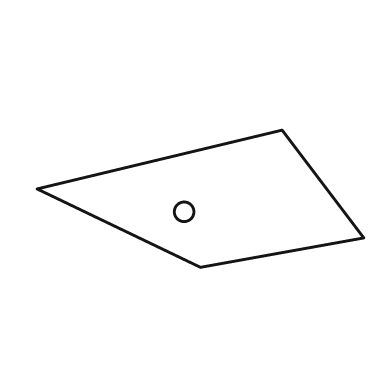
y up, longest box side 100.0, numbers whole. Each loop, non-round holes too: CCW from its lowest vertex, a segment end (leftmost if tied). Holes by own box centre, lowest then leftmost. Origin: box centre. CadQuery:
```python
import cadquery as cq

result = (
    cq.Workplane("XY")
    .moveTo(0.0, -21.0)
    .lineTo(50.0, -12.0)
    .lineTo(25.0, 21.0)
    .lineTo(-50.0, 3.0)
    .close()
    .moveTo(-5.0, -4.0)
    .circle(3.0)
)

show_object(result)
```